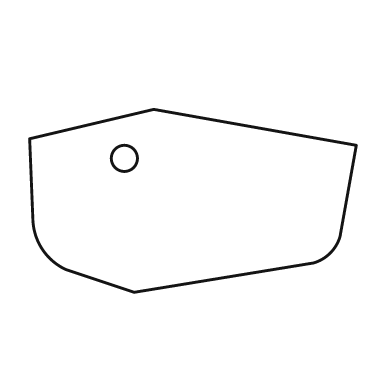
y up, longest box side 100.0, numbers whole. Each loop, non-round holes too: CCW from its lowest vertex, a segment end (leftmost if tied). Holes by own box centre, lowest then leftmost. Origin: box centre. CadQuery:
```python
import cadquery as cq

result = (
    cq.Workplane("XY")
    .moveTo(-18.0, -28.0)
    .lineTo(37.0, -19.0)
    .threePointArc((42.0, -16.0), (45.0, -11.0))
    .lineTo(50.0, 17.0)
    .lineTo(-12.0, 28.0)
    .lineTo(-50.0, 19.0)
    .lineTo(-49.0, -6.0)
    .threePointArc((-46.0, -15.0), (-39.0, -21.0))
    .close()
    .moveTo(-21.0, 13.0)
    .circle(4.0)
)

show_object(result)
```